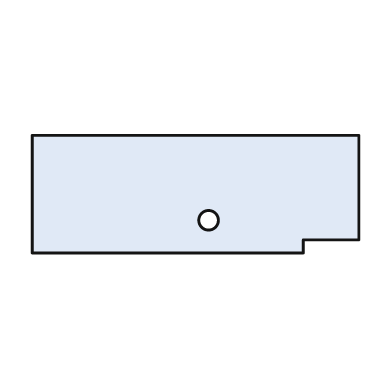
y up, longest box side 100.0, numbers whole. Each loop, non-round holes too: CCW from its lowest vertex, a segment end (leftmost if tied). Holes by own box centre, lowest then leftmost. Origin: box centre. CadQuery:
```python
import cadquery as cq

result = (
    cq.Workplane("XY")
    .moveTo(-50.0, -18.0)
    .lineTo(33.0, -18.0)
    .lineTo(33.0, -14.0)
    .lineTo(50.0, -14.0)
    .lineTo(50.0, 18.0)
    .lineTo(-50.0, 18.0)
    .close()
    .moveTo(4.0, -8.0)
    .circle(3.0)
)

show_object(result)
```